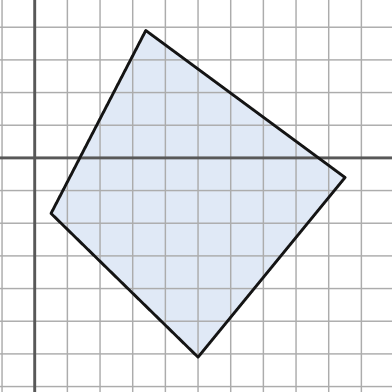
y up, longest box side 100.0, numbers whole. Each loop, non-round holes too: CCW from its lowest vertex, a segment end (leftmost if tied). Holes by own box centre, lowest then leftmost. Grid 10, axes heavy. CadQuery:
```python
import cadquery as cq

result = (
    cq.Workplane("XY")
    .moveTo(50.0, -61.0)
    .lineTo(95.0, -6.0)
    .lineTo(34.0, 39.0)
    .lineTo(5.0, -17.0)
    .close()
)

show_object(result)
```